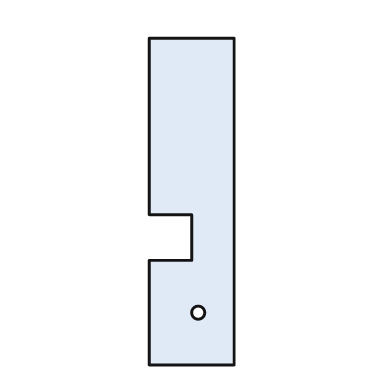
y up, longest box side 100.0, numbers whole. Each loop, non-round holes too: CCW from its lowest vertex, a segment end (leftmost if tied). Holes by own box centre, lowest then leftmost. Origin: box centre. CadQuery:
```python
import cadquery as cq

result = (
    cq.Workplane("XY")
    .moveTo(-13.0, -50.0)
    .lineTo(13.0, -50.0)
    .lineTo(13.0, 50.0)
    .lineTo(-13.0, 50.0)
    .lineTo(-13.0, -4.0)
    .lineTo(0.0, -4.0)
    .lineTo(0.0, -18.0)
    .lineTo(-13.0, -18.0)
    .close()
    .moveTo(2.0, -34.0)
    .circle(2.0)
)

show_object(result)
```